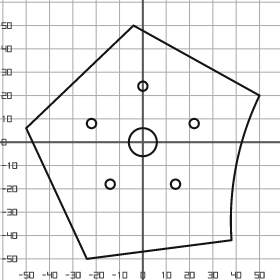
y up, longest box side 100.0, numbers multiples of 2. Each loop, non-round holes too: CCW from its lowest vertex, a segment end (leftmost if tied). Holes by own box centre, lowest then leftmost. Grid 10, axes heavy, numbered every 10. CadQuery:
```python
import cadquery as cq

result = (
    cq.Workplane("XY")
    .moveTo(-24.0, -50.0)
    .lineTo(38.0, -42.0)
    .threePointArc((40.0, -10.0), (50.0, 20.0))
    .lineTo(-4.0, 50.0)
    .lineTo(-50.0, 6.0)
    .close()
    .moveTo(-14.0, -18.0)
    .circle(2.0)
    .moveTo(14.0, -18.0)
    .circle(2.0)
    .moveTo(0.0, 0.0)
    .circle(6.0)
    .moveTo(-22.0, 8.0)
    .circle(2.0)
    .moveTo(22.0, 8.0)
    .circle(2.0)
    .moveTo(0.0, 24.0)
    .circle(2.0)
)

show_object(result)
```